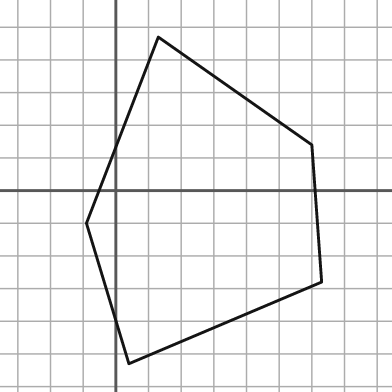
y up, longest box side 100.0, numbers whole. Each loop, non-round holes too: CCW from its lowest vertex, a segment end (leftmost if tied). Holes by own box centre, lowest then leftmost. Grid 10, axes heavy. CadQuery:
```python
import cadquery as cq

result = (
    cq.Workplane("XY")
    .moveTo(4.0, -53.0)
    .lineTo(63.0, -28.0)
    .lineTo(60.0, 14.0)
    .lineTo(13.0, 47.0)
    .lineTo(-9.0, -10.0)
    .close()
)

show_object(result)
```